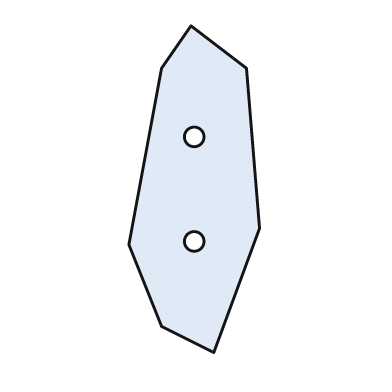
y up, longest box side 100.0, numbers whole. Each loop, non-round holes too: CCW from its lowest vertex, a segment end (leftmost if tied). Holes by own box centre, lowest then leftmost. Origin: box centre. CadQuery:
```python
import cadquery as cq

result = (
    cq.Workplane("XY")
    .moveTo(6.0, -50.0)
    .lineTo(20.0, -12.0)
    .lineTo(16.0, 37.0)
    .lineTo(-1.0, 50.0)
    .lineTo(-10.0, 37.0)
    .lineTo(-20.0, -17.0)
    .lineTo(-10.0, -42.0)
    .close()
    .moveTo(0.0, -16.0)
    .circle(3.0)
    .moveTo(0.0, 16.0)
    .circle(3.0)
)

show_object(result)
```